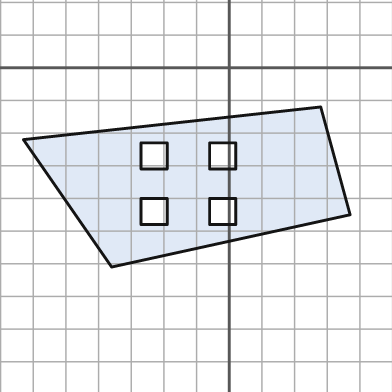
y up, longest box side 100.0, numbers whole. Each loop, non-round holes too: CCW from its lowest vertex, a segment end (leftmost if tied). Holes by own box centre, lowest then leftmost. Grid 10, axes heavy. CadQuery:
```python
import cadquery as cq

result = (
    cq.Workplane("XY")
    .moveTo(-36.0, -61.0)
    .lineTo(37.0, -45.0)
    .lineTo(28.0, -12.0)
    .lineTo(-63.0, -22.0)
    .close()
    .moveTo(-27.0, -48.0)
    .lineTo(-19.0, -48.0)
    .lineTo(-19.0, -40.0)
    .lineTo(-27.0, -40.0)
    .close()
    .moveTo(-6.0, -48.0)
    .lineTo(2.0, -48.0)
    .lineTo(2.0, -40.0)
    .lineTo(-6.0, -40.0)
    .close()
    .moveTo(-27.0, -31.0)
    .lineTo(-19.0, -31.0)
    .lineTo(-19.0, -23.0)
    .lineTo(-27.0, -23.0)
    .close()
    .moveTo(-6.0, -31.0)
    .lineTo(2.0, -31.0)
    .lineTo(2.0, -23.0)
    .lineTo(-6.0, -23.0)
    .close()
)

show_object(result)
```